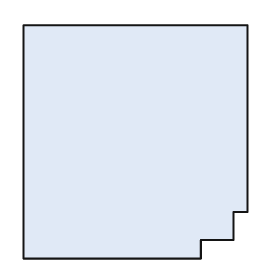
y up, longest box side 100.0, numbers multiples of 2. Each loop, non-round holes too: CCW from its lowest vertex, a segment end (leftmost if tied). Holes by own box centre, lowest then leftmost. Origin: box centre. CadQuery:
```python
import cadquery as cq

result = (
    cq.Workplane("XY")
    .moveTo(-48.0, -50.0)
    .lineTo(28.0, -50.0)
    .lineTo(28.0, -42.0)
    .lineTo(42.0, -42.0)
    .lineTo(42.0, -30.0)
    .lineTo(48.0, -30.0)
    .lineTo(48.0, 50.0)
    .lineTo(-48.0, 50.0)
    .close()
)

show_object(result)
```